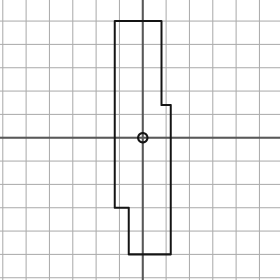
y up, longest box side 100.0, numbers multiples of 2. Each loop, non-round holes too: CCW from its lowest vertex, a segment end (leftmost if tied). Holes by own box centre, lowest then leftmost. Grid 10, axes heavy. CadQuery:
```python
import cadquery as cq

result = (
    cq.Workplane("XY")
    .moveTo(-6.0, -50.0)
    .lineTo(12.0, -50.0)
    .lineTo(12.0, 14.0)
    .lineTo(8.0, 14.0)
    .lineTo(8.0, 50.0)
    .lineTo(-12.0, 50.0)
    .lineTo(-12.0, -30.0)
    .lineTo(-6.0, -30.0)
    .close()
    .moveTo(0.0, 0.0)
    .circle(2.0)
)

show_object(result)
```